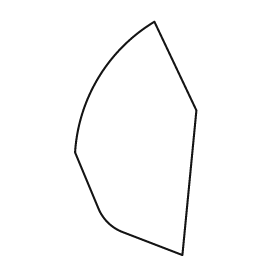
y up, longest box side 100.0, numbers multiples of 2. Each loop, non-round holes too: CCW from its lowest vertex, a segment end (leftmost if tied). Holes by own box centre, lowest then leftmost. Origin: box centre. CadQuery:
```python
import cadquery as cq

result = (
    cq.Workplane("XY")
    .moveTo(20.0, -50.0)
    .lineTo(26.0, 12.0)
    .lineTo(8.0, 50.0)
    .threePointArc((-16.0, 26.0), (-26.0, -6.0))
    .lineTo(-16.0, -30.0)
    .threePointArc((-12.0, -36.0), (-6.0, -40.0))
    .close()
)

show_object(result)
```